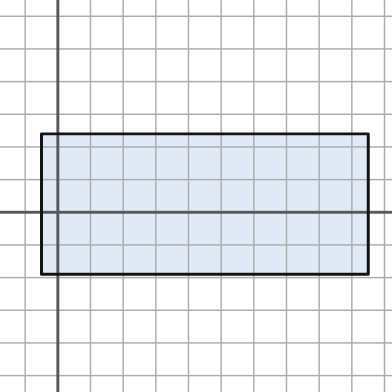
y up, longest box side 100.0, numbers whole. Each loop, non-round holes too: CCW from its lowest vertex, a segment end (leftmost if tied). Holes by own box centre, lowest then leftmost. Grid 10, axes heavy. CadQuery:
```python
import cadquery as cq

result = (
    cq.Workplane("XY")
    .moveTo(-5.0, -19.0)
    .lineTo(95.0, -19.0)
    .lineTo(95.0, 24.0)
    .lineTo(-5.0, 24.0)
    .close()
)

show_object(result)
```